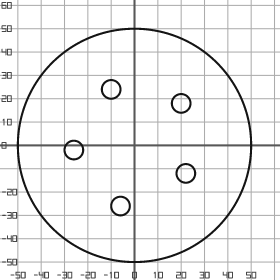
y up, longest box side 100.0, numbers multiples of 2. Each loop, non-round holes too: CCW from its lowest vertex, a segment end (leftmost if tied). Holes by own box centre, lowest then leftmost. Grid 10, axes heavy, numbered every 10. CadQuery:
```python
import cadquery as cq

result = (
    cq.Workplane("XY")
    .moveTo(0.0, 0.0)
    .circle(50.0)
    .moveTo(-6.0, -26.0)
    .circle(4.0)
    .moveTo(22.0, -12.0)
    .circle(4.0)
    .moveTo(-26.0, -2.0)
    .circle(4.0)
    .moveTo(20.0, 18.0)
    .circle(4.0)
    .moveTo(-10.0, 24.0)
    .circle(4.0)
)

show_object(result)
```